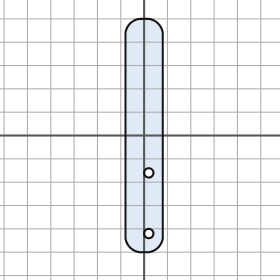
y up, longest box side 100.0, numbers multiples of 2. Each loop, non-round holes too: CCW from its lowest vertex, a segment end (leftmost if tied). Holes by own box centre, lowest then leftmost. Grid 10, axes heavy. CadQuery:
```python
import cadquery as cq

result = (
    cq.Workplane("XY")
    .moveTo(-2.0, -50.0)
    .lineTo(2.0, -50.0)
    .threePointArc((6.0, -48.0), (8.0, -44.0))
    .lineTo(8.0, 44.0)
    .threePointArc((6.0, 48.0), (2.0, 50.0))
    .lineTo(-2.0, 50.0)
    .threePointArc((-6.0, 48.0), (-8.0, 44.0))
    .lineTo(-8.0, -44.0)
    .threePointArc((-6.0, -48.0), (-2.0, -50.0))
    .close()
    .moveTo(2.0, -42.0)
    .circle(2.0)
    .moveTo(2.0, -16.0)
    .circle(2.0)
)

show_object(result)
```